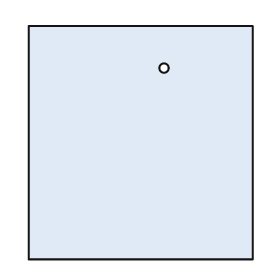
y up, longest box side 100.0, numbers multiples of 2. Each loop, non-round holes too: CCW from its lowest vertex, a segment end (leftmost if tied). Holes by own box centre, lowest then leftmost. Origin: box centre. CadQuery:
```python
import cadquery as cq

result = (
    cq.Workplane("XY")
    .moveTo(-48.0, -50.0)
    .lineTo(48.0, -50.0)
    .lineTo(48.0, 50.0)
    .lineTo(-48.0, 50.0)
    .close()
    .moveTo(10.0, 32.0)
    .circle(2.0)
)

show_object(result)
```